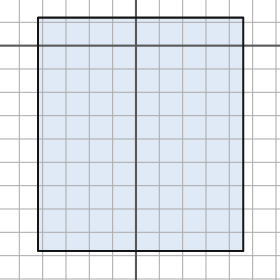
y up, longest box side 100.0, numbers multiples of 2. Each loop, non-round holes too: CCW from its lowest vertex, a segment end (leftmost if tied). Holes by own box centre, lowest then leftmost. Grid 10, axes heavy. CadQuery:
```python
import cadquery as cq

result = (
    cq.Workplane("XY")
    .moveTo(-42.0, -88.0)
    .lineTo(46.0, -88.0)
    .lineTo(46.0, 12.0)
    .lineTo(-42.0, 12.0)
    .close()
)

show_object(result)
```